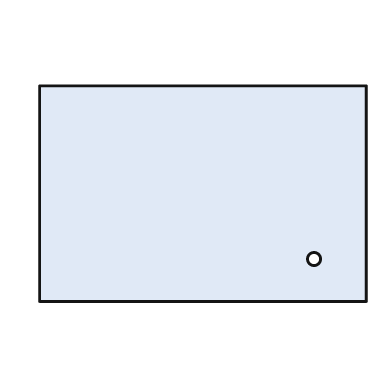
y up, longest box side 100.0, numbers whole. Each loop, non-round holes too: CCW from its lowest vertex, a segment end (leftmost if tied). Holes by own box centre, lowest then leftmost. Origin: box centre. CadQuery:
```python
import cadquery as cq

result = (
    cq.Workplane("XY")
    .moveTo(-50.0, -33.0)
    .lineTo(50.0, -33.0)
    .lineTo(50.0, 33.0)
    .lineTo(-50.0, 33.0)
    .close()
    .moveTo(34.0, -20.0)
    .circle(2.0)
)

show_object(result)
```